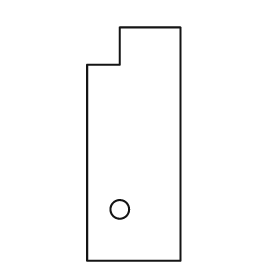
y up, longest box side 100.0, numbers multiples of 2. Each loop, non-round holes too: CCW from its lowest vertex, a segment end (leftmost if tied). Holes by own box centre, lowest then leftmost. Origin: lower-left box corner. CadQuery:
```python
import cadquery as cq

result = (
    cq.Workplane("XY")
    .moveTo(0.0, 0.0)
    .lineTo(40.0, 0.0)
    .lineTo(40.0, 100.0)
    .lineTo(14.0, 100.0)
    .lineTo(14.0, 84.0)
    .lineTo(0.0, 84.0)
    .close()
    .moveTo(14.0, 22.0)
    .circle(4.0)
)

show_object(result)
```